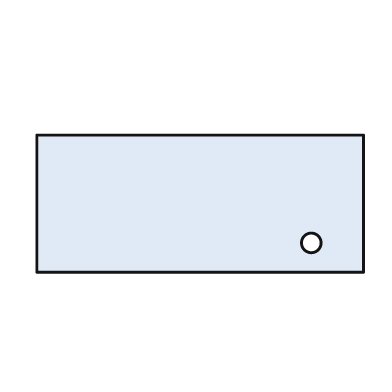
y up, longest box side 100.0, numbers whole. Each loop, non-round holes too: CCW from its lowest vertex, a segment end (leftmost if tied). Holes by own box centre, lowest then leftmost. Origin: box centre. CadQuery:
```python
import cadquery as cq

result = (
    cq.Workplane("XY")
    .moveTo(-50.0, -21.0)
    .lineTo(50.0, -21.0)
    .lineTo(50.0, 21.0)
    .lineTo(-50.0, 21.0)
    .close()
    .moveTo(34.0, -12.0)
    .circle(3.0)
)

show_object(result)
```